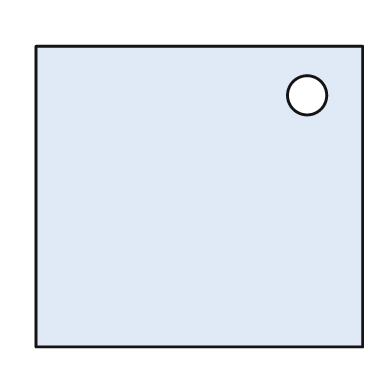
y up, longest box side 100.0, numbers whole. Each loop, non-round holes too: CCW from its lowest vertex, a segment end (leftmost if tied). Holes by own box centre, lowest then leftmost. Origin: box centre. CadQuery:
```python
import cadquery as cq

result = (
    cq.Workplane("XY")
    .moveTo(-50.0, -46.0)
    .lineTo(50.0, -46.0)
    .lineTo(50.0, 46.0)
    .lineTo(-50.0, 46.0)
    .close()
    .moveTo(33.0, 31.0)
    .circle(6.0)
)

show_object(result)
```